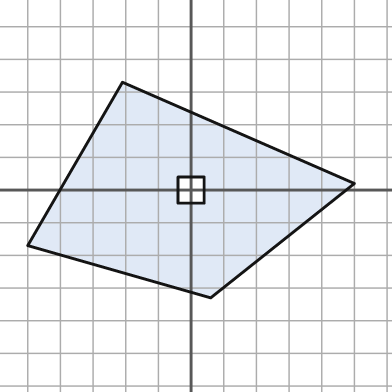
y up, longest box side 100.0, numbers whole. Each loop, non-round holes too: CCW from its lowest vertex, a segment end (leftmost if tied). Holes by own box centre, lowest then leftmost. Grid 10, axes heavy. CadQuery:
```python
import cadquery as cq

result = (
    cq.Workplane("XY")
    .moveTo(6.0, -33.0)
    .lineTo(50.0, 2.0)
    .lineTo(-21.0, 33.0)
    .lineTo(-50.0, -17.0)
    .close()
    .moveTo(-4.0, -4.0)
    .lineTo(4.0, -4.0)
    .lineTo(4.0, 4.0)
    .lineTo(-4.0, 4.0)
    .close()
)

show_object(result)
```